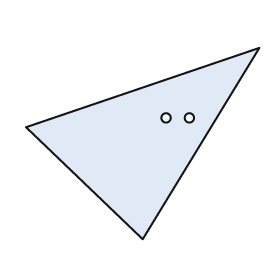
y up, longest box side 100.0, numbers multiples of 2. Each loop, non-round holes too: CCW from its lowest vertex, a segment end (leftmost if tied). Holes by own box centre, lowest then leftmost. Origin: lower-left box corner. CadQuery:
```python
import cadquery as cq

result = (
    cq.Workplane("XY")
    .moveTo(50.0, 0.0)
    .lineTo(100.0, 82.0)
    .lineTo(0.0, 48.0)
    .close()
    .moveTo(60.0, 52.0)
    .circle(2.0)
    .moveTo(70.0, 52.0)
    .circle(2.0)
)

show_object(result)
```